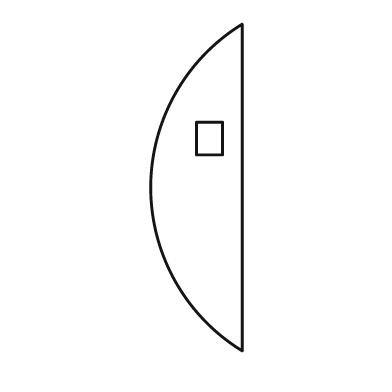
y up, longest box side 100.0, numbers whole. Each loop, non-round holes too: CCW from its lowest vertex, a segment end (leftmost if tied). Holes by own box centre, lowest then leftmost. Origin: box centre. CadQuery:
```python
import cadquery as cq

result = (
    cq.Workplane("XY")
    .moveTo(14.0, -50.0)
    .lineTo(14.0, 50.0)
    .threePointArc((-14.0, 0.0), (14.0, -50.0))
    .close()
    .moveTo(0.0, 10.0)
    .lineTo(8.0, 10.0)
    .lineTo(8.0, 20.0)
    .lineTo(0.0, 20.0)
    .close()
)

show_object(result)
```